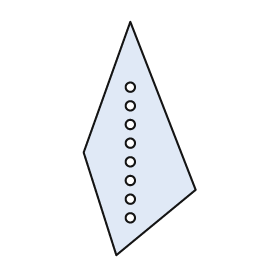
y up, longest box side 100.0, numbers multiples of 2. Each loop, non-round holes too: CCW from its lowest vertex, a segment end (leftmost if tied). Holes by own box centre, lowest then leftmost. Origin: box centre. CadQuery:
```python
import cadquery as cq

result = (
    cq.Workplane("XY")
    .moveTo(-10.0, -50.0)
    .lineTo(24.0, -22.0)
    .lineTo(-4.0, 50.0)
    .lineTo(-24.0, -6.0)
    .close()
    .moveTo(-4.0, -34.0)
    .circle(2.0)
    .moveTo(-4.0, -26.0)
    .circle(2.0)
    .moveTo(-4.0, -18.0)
    .circle(2.0)
    .moveTo(-4.0, -10.0)
    .circle(2.0)
    .moveTo(-4.0, -2.0)
    .circle(2.0)
    .moveTo(-4.0, 6.0)
    .circle(2.0)
    .moveTo(-4.0, 14.0)
    .circle(2.0)
    .moveTo(-4.0, 22.0)
    .circle(2.0)
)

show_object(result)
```